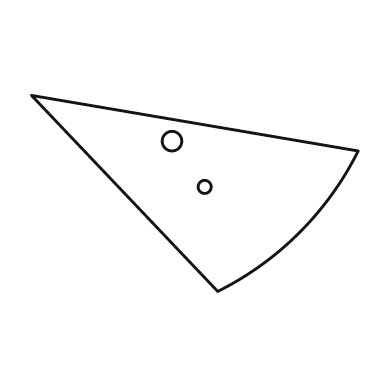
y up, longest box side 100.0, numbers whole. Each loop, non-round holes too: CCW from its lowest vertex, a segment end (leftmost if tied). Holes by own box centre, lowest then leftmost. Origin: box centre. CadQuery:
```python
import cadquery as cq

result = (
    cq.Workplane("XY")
    .moveTo(7.0, -30.0)
    .threePointArc((32.0, -12.0), (50.0, 13.0))
    .lineTo(-50.0, 30.0)
    .close()
    .moveTo(3.0, 2.0)
    .circle(2.0)
    .moveTo(-7.0, 16.0)
    .circle(3.0)
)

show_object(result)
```